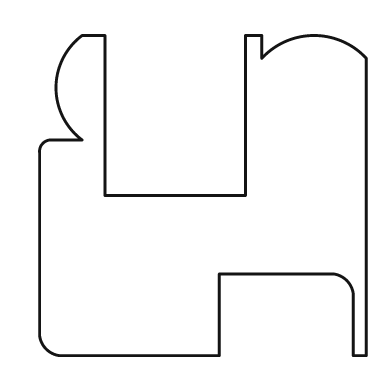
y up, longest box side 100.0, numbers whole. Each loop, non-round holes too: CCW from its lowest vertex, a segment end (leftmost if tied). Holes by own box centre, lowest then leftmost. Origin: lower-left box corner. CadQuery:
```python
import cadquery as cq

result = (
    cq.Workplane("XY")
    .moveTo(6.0, 0.0)
    .lineTo(55.0, 0.0)
    .lineTo(55.0, 25.0)
    .lineTo(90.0, 25.0)
    .threePointArc((94.0, 23.0), (96.0, 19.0))
    .lineTo(96.0, 0.0)
    .lineTo(100.0, 0.0)
    .lineTo(100.0, 91.0)
    .threePointArc((84.0, 98.0), (68.0, 91.0))
    .lineTo(68.0, 98.0)
    .lineTo(63.0, 98.0)
    .lineTo(63.0, 49.0)
    .lineTo(20.0, 49.0)
    .lineTo(20.0, 98.0)
    .lineTo(13.0, 98.0)
    .threePointArc((5.0, 82.0), (13.0, 66.0))
    .lineTo(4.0, 66.0)
    .threePointArc((1.0, 65.0), (0.0, 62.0))
    .lineTo(0.0, 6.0)
    .threePointArc((2.0, 2.0), (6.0, 0.0))
    .close()
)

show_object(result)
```